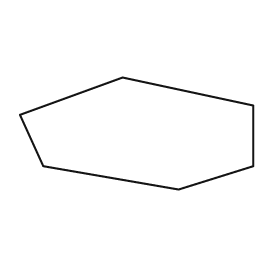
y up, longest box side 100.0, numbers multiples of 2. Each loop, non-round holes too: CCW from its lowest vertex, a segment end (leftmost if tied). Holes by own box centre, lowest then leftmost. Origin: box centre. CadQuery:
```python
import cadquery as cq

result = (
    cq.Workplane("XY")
    .moveTo(18.0, -24.0)
    .lineTo(50.0, -14.0)
    .lineTo(50.0, 12.0)
    .lineTo(-6.0, 24.0)
    .lineTo(-50.0, 8.0)
    .lineTo(-40.0, -14.0)
    .close()
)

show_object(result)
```